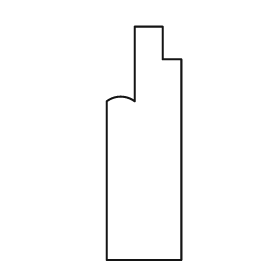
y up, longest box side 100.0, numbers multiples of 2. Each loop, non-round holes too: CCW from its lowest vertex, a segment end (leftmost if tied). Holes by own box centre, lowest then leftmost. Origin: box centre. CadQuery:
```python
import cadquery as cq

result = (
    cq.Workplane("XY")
    .moveTo(-16.0, -50.0)
    .lineTo(16.0, -50.0)
    .lineTo(16.0, 36.0)
    .lineTo(8.0, 36.0)
    .lineTo(8.0, 50.0)
    .lineTo(-4.0, 50.0)
    .lineTo(-4.0, 18.0)
    .threePointArc((-10.0, 20.0), (-16.0, 18.0))
    .close()
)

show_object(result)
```